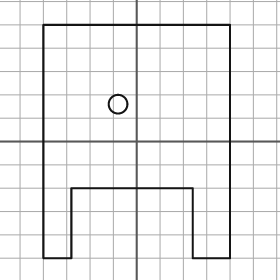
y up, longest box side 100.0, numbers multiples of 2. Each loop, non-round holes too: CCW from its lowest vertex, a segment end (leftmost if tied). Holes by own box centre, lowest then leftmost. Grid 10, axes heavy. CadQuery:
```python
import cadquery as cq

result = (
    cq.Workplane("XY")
    .moveTo(-40.0, -50.0)
    .lineTo(-28.0, -50.0)
    .lineTo(-28.0, -20.0)
    .lineTo(24.0, -20.0)
    .lineTo(24.0, -50.0)
    .lineTo(40.0, -50.0)
    .lineTo(40.0, 50.0)
    .lineTo(-40.0, 50.0)
    .close()
    .moveTo(-8.0, 16.0)
    .circle(4.0)
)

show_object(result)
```